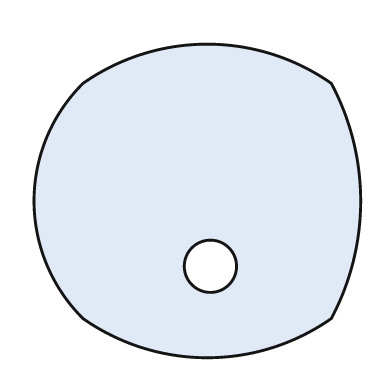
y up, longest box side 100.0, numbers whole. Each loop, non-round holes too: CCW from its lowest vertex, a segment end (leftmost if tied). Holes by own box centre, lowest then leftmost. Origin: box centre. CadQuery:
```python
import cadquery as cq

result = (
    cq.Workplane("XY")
    .moveTo(-35.0, -36.0)
    .threePointArc((3.0, -48.0), (41.0, -36.0))
    .threePointArc((50.0, 0.0), (41.0, 36.0))
    .threePointArc((3.0, 48.0), (-35.0, 36.0))
    .threePointArc((-50.0, 0.0), (-35.0, -36.0))
    .close()
    .moveTo(4.0, -20.0)
    .circle(8.0)
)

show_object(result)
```